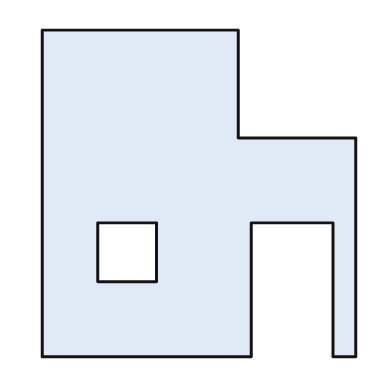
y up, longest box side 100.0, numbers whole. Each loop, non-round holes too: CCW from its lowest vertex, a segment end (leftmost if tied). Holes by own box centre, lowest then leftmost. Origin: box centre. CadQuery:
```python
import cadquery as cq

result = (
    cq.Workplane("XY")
    .moveTo(-48.0, -50.0)
    .lineTo(16.0, -50.0)
    .lineTo(16.0, -9.0)
    .lineTo(41.0, -9.0)
    .lineTo(41.0, -50.0)
    .lineTo(48.0, -50.0)
    .lineTo(48.0, 17.0)
    .lineTo(12.0, 17.0)
    .lineTo(12.0, 50.0)
    .lineTo(-48.0, 50.0)
    .close()
    .moveTo(-31.0, -27.0)
    .lineTo(-13.0, -27.0)
    .lineTo(-13.0, -9.0)
    .lineTo(-31.0, -9.0)
    .close()
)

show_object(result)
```